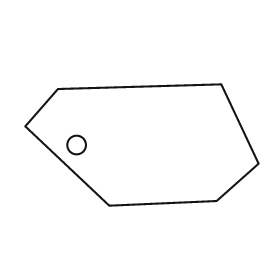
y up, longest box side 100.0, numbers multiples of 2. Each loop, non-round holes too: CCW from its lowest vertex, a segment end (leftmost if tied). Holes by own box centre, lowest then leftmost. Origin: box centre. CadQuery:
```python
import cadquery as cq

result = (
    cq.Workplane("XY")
    .moveTo(-14.0, -26.0)
    .lineTo(32.0, -24.0)
    .lineTo(50.0, -8.0)
    .lineTo(34.0, 26.0)
    .lineTo(-36.0, 24.0)
    .lineTo(-50.0, 8.0)
    .close()
    .moveTo(-28.0, 0.0)
    .circle(4.0)
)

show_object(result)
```